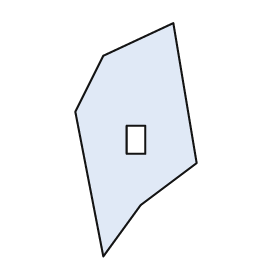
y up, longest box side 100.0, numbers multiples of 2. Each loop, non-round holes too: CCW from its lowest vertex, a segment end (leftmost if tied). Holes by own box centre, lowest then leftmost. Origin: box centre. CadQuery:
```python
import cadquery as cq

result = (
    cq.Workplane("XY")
    .moveTo(-14.0, -50.0)
    .lineTo(2.0, -28.0)
    .lineTo(26.0, -10.0)
    .lineTo(16.0, 50.0)
    .lineTo(-14.0, 36.0)
    .lineTo(-26.0, 12.0)
    .close()
    .moveTo(-4.0, -6.0)
    .lineTo(4.0, -6.0)
    .lineTo(4.0, 6.0)
    .lineTo(-4.0, 6.0)
    .close()
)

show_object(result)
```